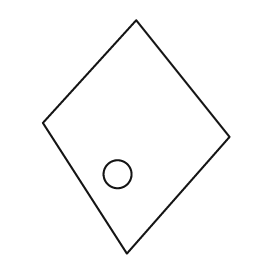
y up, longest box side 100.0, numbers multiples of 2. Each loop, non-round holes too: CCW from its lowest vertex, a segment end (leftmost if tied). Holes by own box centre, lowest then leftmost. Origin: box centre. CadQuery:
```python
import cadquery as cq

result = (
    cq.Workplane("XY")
    .moveTo(-4.0, -50.0)
    .lineTo(40.0, 0.0)
    .lineTo(0.0, 50.0)
    .lineTo(-40.0, 6.0)
    .close()
    .moveTo(-8.0, -16.0)
    .circle(6.0)
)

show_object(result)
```